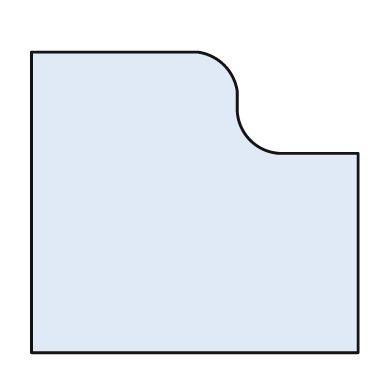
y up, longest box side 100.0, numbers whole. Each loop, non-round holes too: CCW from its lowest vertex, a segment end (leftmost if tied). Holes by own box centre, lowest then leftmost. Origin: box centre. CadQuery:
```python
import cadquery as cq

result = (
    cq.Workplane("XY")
    .moveTo(-50.0, -46.0)
    .lineTo(50.0, -46.0)
    .lineTo(50.0, 15.0)
    .lineTo(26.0, 15.0)
    .threePointArc((17.0, 19.0), (13.0, 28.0))
    .lineTo(13.0, 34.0)
    .threePointArc((9.0, 42.0), (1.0, 46.0))
    .lineTo(-50.0, 46.0)
    .close()
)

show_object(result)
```